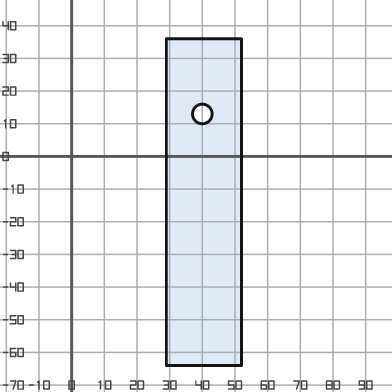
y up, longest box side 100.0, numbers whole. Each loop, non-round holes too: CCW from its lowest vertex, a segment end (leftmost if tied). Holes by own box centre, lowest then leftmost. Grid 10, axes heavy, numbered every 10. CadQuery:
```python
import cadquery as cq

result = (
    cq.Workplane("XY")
    .moveTo(29.0, -64.0)
    .lineTo(52.0, -64.0)
    .lineTo(52.0, 36.0)
    .lineTo(29.0, 36.0)
    .close()
    .moveTo(40.0, 13.0)
    .circle(3.0)
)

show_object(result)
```